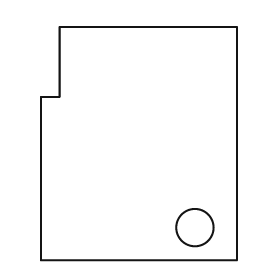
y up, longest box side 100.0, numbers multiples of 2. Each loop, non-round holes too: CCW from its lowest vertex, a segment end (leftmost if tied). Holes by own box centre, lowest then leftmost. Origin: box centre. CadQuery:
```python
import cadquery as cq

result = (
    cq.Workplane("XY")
    .moveTo(-42.0, -50.0)
    .lineTo(42.0, -50.0)
    .lineTo(42.0, 50.0)
    .lineTo(-34.0, 50.0)
    .lineTo(-34.0, 20.0)
    .lineTo(-42.0, 20.0)
    .close()
    .moveTo(24.0, -36.0)
    .circle(8.0)
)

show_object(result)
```